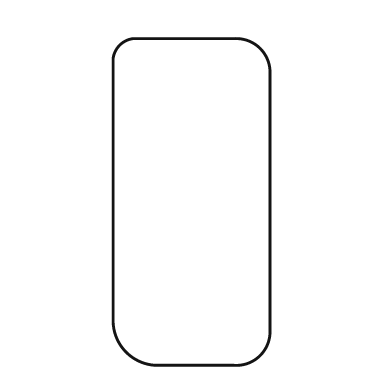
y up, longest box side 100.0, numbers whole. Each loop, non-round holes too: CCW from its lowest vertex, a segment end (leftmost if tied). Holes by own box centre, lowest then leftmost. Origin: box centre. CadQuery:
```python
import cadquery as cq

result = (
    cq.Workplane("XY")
    .moveTo(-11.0, -50.0)
    .lineTo(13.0, -50.0)
    .threePointArc((21.0, -47.0), (24.0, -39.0))
    .lineTo(24.0, 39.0)
    .threePointArc((21.0, 47.0), (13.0, 50.0))
    .lineTo(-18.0, 50.0)
    .threePointArc((-22.0, 48.0), (-24.0, 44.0))
    .lineTo(-24.0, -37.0)
    .threePointArc((-20.0, -46.0), (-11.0, -50.0))
    .close()
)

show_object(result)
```